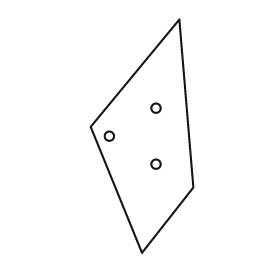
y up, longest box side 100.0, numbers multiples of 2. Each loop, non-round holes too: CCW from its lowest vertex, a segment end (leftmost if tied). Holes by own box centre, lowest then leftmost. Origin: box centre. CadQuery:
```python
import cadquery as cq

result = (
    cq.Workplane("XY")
    .moveTo(0.0, -50.0)
    .lineTo(22.0, -22.0)
    .lineTo(16.0, 50.0)
    .lineTo(-22.0, 4.0)
    .close()
    .moveTo(6.0, -12.0)
    .circle(2.0)
    .moveTo(-14.0, 0.0)
    .circle(2.0)
    .moveTo(6.0, 12.0)
    .circle(2.0)
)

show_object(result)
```